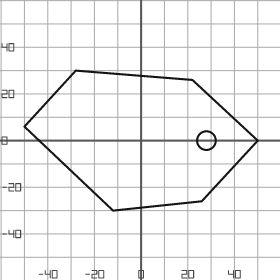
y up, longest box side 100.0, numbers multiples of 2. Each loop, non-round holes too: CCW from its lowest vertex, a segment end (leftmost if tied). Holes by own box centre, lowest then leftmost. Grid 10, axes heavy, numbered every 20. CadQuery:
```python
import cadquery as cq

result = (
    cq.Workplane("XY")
    .moveTo(-12.0, -30.0)
    .lineTo(26.0, -26.0)
    .lineTo(50.0, 0.0)
    .lineTo(22.0, 26.0)
    .lineTo(-28.0, 30.0)
    .lineTo(-50.0, 6.0)
    .close()
    .moveTo(28.0, 0.0)
    .circle(4.0)
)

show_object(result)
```